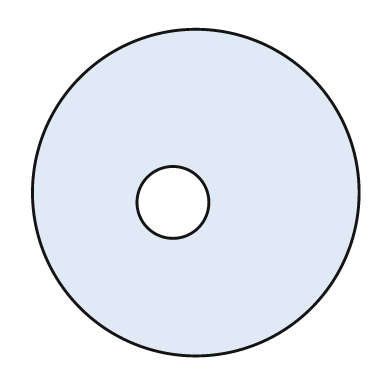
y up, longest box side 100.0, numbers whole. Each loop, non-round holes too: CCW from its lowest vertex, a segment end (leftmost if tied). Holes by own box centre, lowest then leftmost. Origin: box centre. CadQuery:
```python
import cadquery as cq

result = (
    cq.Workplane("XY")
    .moveTo(0.0, 0.0)
    .circle(50.0)
    .moveTo(-7.0, -3.0)
    .circle(11.0)
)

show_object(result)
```